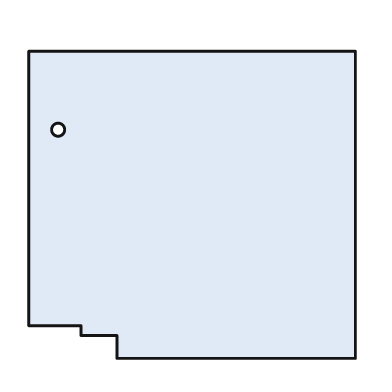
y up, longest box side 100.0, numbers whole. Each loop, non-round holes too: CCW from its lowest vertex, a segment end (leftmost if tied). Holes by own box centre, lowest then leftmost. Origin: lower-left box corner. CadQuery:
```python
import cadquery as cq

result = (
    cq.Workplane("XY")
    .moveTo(27.0, 0.0)
    .lineTo(100.0, 0.0)
    .lineTo(100.0, 94.0)
    .lineTo(0.0, 94.0)
    .lineTo(0.0, 10.0)
    .lineTo(16.0, 10.0)
    .lineTo(16.0, 7.0)
    .lineTo(27.0, 7.0)
    .close()
    .moveTo(9.0, 70.0)
    .circle(2.0)
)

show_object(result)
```